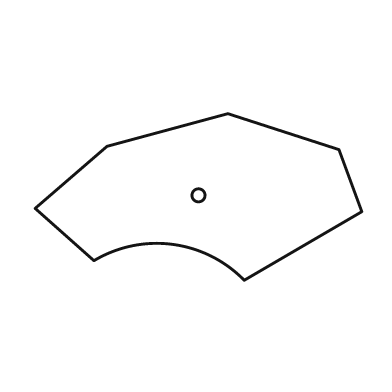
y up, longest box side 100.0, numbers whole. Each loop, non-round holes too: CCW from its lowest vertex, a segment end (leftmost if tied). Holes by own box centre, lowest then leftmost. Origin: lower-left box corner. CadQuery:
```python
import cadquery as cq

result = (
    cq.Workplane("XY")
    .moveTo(64.0, 0.0)
    .lineTo(100.0, 21.0)
    .lineTo(93.0, 40.0)
    .lineTo(59.0, 51.0)
    .lineTo(22.0, 41.0)
    .lineTo(0.0, 22.0)
    .lineTo(18.0, 6.0)
    .threePointArc((42.0, 11.0), (64.0, 0.0))
    .close()
    .moveTo(50.0, 26.0)
    .circle(2.0)
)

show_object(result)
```